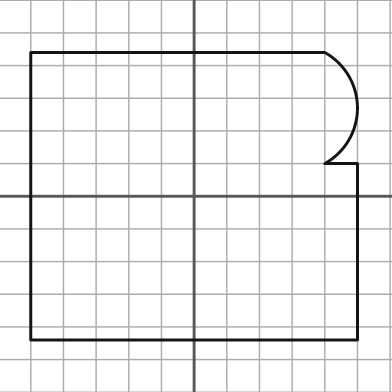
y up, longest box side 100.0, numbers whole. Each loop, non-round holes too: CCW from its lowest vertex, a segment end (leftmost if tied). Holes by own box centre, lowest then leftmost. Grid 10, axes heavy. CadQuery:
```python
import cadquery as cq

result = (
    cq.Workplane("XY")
    .moveTo(-50.0, -44.0)
    .lineTo(50.0, -44.0)
    .lineTo(50.0, 10.0)
    .lineTo(40.0, 10.0)
    .threePointArc((50.0, 27.0), (40.0, 44.0))
    .lineTo(-50.0, 44.0)
    .close()
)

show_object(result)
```